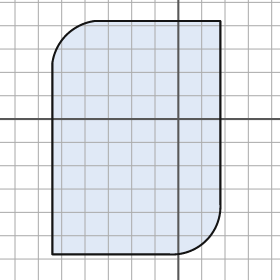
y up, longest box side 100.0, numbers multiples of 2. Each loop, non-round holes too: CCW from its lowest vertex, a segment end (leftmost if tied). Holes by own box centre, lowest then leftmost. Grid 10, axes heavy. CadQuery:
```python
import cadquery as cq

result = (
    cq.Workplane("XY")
    .moveTo(-54.0, -58.0)
    .lineTo(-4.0, -58.0)
    .threePointArc((12.0, -52.0), (18.0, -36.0))
    .lineTo(18.0, 42.0)
    .lineTo(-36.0, 42.0)
    .threePointArc((-48.0, 36.0), (-54.0, 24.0))
    .close()
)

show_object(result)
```